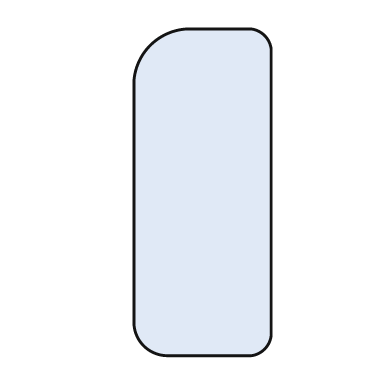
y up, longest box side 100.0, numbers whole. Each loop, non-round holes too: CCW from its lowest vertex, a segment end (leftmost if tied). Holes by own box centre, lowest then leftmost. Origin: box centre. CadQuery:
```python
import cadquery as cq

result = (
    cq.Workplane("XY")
    .moveTo(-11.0, -50.0)
    .lineTo(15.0, -50.0)
    .threePointArc((19.0, -48.0), (21.0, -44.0))
    .lineTo(21.0, 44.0)
    .threePointArc((19.0, 48.0), (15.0, 50.0))
    .lineTo(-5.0, 50.0)
    .threePointArc((-16.0, 45.0), (-21.0, 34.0))
    .lineTo(-21.0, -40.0)
    .threePointArc((-18.0, -47.0), (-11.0, -50.0))
    .close()
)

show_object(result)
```